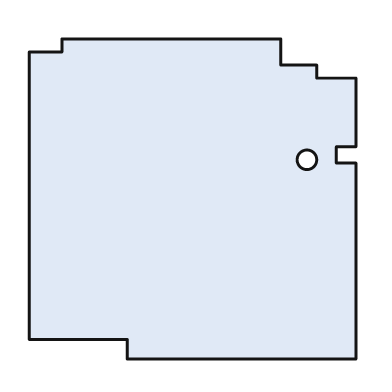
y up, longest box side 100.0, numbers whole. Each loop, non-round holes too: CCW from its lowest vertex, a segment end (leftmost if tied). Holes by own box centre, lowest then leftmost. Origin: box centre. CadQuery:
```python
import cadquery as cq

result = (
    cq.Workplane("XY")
    .moveTo(-20.0, -49.0)
    .lineTo(50.0, -49.0)
    .lineTo(50.0, 11.0)
    .lineTo(44.0, 11.0)
    .lineTo(44.0, 16.0)
    .lineTo(50.0, 16.0)
    .lineTo(50.0, 37.0)
    .lineTo(38.0, 37.0)
    .lineTo(38.0, 41.0)
    .lineTo(27.0, 41.0)
    .lineTo(27.0, 49.0)
    .lineTo(-40.0, 49.0)
    .lineTo(-40.0, 45.0)
    .lineTo(-50.0, 45.0)
    .lineTo(-50.0, -43.0)
    .lineTo(-20.0, -43.0)
    .close()
    .moveTo(35.0, 12.0)
    .circle(3.0)
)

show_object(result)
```